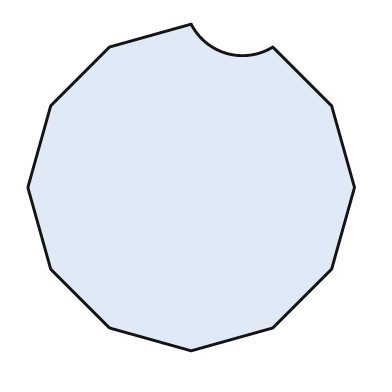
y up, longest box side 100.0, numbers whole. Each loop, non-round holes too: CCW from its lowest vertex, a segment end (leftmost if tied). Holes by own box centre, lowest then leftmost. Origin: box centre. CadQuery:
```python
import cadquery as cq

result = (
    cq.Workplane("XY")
    .moveTo(0.0, -50.0)
    .lineTo(25.0, -43.0)
    .lineTo(43.0, -25.0)
    .lineTo(50.0, 0.0)
    .lineTo(43.0, 25.0)
    .lineTo(25.0, 43.0)
    .threePointArc((11.0, 41.0), (0.0, 50.0))
    .lineTo(-25.0, 43.0)
    .lineTo(-43.0, 25.0)
    .lineTo(-50.0, 0.0)
    .lineTo(-43.0, -25.0)
    .lineTo(-25.0, -43.0)
    .close()
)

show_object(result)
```